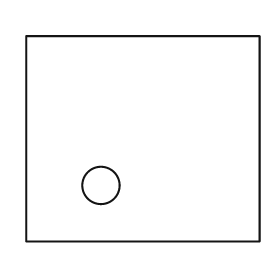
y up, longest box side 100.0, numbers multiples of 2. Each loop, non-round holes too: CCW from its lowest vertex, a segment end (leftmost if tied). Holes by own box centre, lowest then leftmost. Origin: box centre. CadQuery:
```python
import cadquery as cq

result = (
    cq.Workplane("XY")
    .moveTo(-50.0, -44.0)
    .lineTo(50.0, -44.0)
    .lineTo(50.0, 44.0)
    .lineTo(-50.0, 44.0)
    .close()
    .moveTo(-18.0, -20.0)
    .circle(8.0)
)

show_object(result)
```